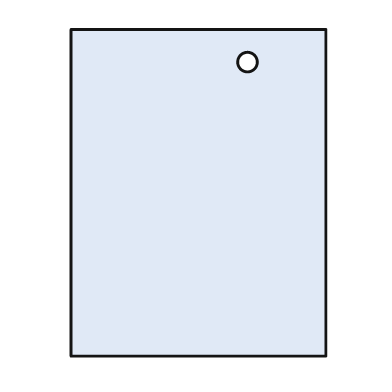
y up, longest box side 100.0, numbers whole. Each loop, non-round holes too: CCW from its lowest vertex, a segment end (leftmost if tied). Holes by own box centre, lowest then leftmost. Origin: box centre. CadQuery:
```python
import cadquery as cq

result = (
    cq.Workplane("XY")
    .moveTo(-39.0, -50.0)
    .lineTo(39.0, -50.0)
    .lineTo(39.0, 50.0)
    .lineTo(-39.0, 50.0)
    .close()
    .moveTo(15.0, 40.0)
    .circle(3.0)
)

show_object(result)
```